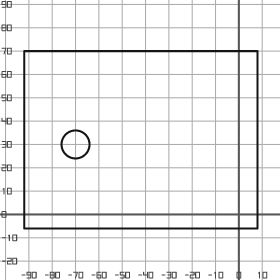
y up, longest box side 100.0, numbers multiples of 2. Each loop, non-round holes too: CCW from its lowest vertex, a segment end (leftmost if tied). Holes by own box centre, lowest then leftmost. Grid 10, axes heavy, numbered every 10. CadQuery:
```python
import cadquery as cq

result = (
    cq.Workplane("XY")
    .moveTo(-92.0, -6.0)
    .lineTo(8.0, -6.0)
    .lineTo(8.0, 70.0)
    .lineTo(-92.0, 70.0)
    .close()
    .moveTo(-70.0, 30.0)
    .circle(6.0)
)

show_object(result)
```